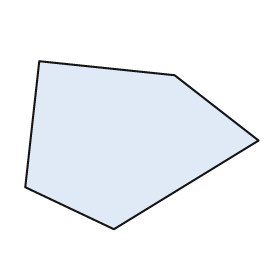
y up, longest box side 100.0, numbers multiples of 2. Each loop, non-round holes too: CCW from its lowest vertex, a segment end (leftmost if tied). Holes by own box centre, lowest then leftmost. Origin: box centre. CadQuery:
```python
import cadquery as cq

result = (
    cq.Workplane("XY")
    .moveTo(-12.0, -36.0)
    .lineTo(50.0, 2.0)
    .lineTo(14.0, 30.0)
    .lineTo(-44.0, 36.0)
    .lineTo(-50.0, -18.0)
    .close()
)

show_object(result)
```